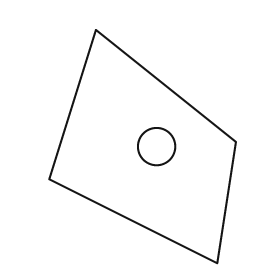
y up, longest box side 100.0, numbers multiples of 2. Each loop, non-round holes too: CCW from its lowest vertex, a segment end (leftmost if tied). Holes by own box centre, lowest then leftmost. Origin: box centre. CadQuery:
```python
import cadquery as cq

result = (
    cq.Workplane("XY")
    .moveTo(32.0, -50.0)
    .lineTo(40.0, 2.0)
    .lineTo(-20.0, 50.0)
    .lineTo(-40.0, -14.0)
    .close()
    .moveTo(6.0, 0.0)
    .circle(8.0)
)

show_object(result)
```